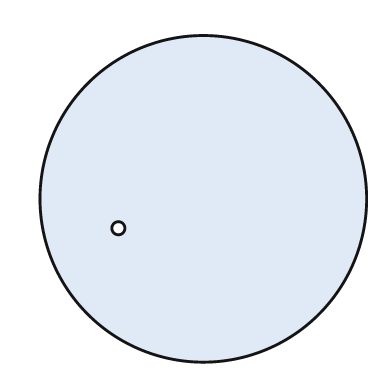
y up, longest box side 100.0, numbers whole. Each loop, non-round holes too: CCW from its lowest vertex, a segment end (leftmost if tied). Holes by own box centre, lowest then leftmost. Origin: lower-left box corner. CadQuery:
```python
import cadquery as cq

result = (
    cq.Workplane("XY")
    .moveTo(50.0, 50.0)
    .circle(50.0)
    .moveTo(24.0, 41.0)
    .circle(2.0)
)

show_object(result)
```